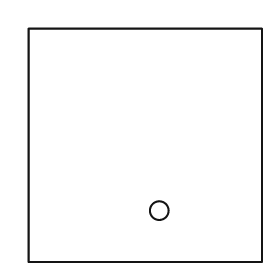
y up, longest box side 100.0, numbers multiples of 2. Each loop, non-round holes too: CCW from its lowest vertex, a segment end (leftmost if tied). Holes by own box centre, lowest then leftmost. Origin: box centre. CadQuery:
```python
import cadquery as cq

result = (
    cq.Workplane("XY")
    .moveTo(-50.0, -50.0)
    .lineTo(50.0, -50.0)
    .lineTo(50.0, 50.0)
    .lineTo(-50.0, 50.0)
    .close()
    .moveTo(6.0, -28.0)
    .circle(4.0)
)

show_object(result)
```